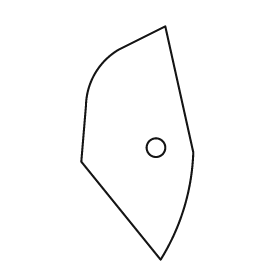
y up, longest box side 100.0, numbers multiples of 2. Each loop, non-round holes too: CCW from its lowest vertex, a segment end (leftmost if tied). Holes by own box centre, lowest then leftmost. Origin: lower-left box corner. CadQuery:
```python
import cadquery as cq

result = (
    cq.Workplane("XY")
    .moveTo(34.0, 0.0)
    .threePointArc((44.0, 22.0), (48.0, 46.0))
    .lineTo(36.0, 100.0)
    .lineTo(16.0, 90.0)
    .threePointArc((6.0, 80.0), (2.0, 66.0))
    .lineTo(0.0, 42.0)
    .close()
    .moveTo(32.0, 48.0)
    .circle(4.0)
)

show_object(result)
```